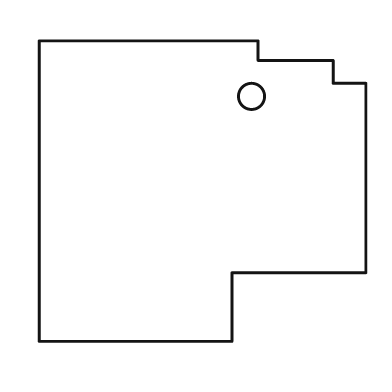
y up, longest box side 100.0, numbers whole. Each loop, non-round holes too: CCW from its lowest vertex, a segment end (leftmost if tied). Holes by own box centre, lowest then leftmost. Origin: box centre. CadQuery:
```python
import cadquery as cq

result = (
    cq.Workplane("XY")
    .moveTo(-50.0, -46.0)
    .lineTo(9.0, -46.0)
    .lineTo(9.0, -25.0)
    .lineTo(50.0, -25.0)
    .lineTo(50.0, 33.0)
    .lineTo(40.0, 33.0)
    .lineTo(40.0, 40.0)
    .lineTo(17.0, 40.0)
    .lineTo(17.0, 46.0)
    .lineTo(-50.0, 46.0)
    .close()
    .moveTo(15.0, 29.0)
    .circle(4.0)
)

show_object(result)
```